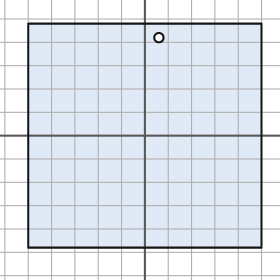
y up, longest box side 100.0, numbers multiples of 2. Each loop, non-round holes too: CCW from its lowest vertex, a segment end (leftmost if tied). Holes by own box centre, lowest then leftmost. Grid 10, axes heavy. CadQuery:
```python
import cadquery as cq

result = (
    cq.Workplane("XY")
    .moveTo(-50.0, -48.0)
    .lineTo(50.0, -48.0)
    .lineTo(50.0, 48.0)
    .lineTo(-50.0, 48.0)
    .close()
    .moveTo(6.0, 42.0)
    .circle(2.0)
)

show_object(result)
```